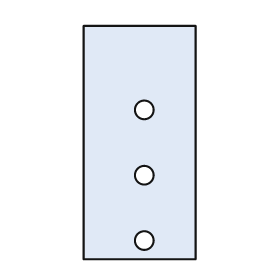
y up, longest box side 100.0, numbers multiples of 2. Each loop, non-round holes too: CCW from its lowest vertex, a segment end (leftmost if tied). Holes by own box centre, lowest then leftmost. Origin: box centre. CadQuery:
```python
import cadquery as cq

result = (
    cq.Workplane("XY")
    .moveTo(-24.0, -50.0)
    .lineTo(24.0, -50.0)
    .lineTo(24.0, 50.0)
    .lineTo(-24.0, 50.0)
    .close()
    .moveTo(2.0, -42.0)
    .circle(4.0)
    .moveTo(2.0, -14.0)
    .circle(4.0)
    .moveTo(2.0, 14.0)
    .circle(4.0)
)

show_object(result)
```